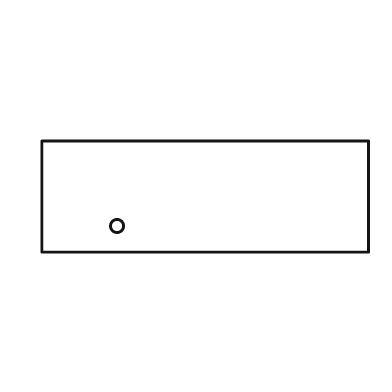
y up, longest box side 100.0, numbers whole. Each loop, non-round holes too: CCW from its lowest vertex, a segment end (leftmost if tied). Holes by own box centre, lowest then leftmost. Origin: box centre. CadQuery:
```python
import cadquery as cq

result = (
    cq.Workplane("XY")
    .moveTo(-50.0, -17.0)
    .lineTo(50.0, -17.0)
    .lineTo(50.0, 17.0)
    .lineTo(-50.0, 17.0)
    .close()
    .moveTo(-27.0, -9.0)
    .circle(2.0)
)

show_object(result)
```